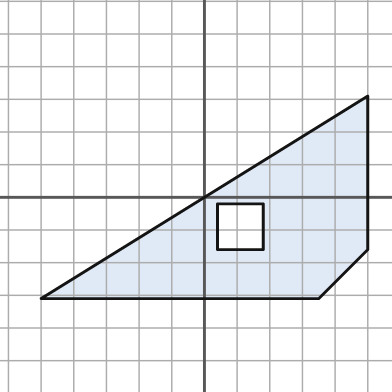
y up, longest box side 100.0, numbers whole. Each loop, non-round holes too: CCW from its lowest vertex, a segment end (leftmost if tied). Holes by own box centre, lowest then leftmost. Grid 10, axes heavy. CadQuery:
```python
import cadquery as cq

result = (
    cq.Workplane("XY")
    .moveTo(-50.0, -31.0)
    .lineTo(35.0, -31.0)
    .lineTo(50.0, -16.0)
    .lineTo(50.0, 31.0)
    .close()
    .moveTo(4.0, -16.0)
    .lineTo(18.0, -16.0)
    .lineTo(18.0, -2.0)
    .lineTo(4.0, -2.0)
    .close()
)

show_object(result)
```